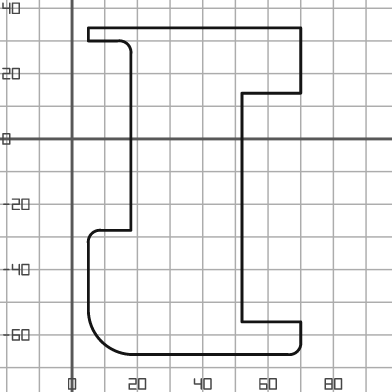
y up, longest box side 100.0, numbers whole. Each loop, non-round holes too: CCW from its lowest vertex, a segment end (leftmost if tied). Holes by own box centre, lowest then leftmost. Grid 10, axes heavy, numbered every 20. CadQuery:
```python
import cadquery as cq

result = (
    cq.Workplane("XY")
    .moveTo(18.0, -66.0)
    .lineTo(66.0, -66.0)
    .threePointArc((69.0, -65.0), (70.0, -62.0))
    .lineTo(70.0, -56.0)
    .lineTo(52.0, -56.0)
    .lineTo(52.0, 14.0)
    .lineTo(70.0, 14.0)
    .lineTo(70.0, 34.0)
    .lineTo(5.0, 34.0)
    .lineTo(5.0, 30.0)
    .lineTo(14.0, 30.0)
    .threePointArc((17.0, 29.0), (18.0, 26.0))
    .lineTo(18.0, -28.0)
    .lineTo(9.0, -28.0)
    .threePointArc((6.0, -29.0), (5.0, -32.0))
    .lineTo(5.0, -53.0)
    .threePointArc((9.0, -62.0), (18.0, -66.0))
    .close()
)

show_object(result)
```